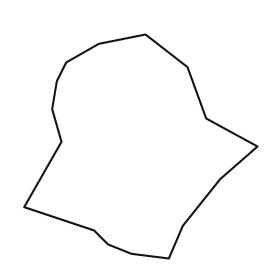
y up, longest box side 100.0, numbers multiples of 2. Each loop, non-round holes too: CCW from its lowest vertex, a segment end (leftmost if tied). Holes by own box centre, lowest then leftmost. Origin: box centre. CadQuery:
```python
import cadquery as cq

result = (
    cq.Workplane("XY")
    .moveTo(12.0, -48.0)
    .lineTo(18.0, -34.0)
    .lineTo(34.0, -14.0)
    .lineTo(50.0, 0.0)
    .lineTo(28.0, 12.0)
    .lineTo(20.0, 34.0)
    .lineTo(2.0, 48.0)
    .lineTo(-18.0, 44.0)
    .lineTo(-32.0, 36.0)
    .lineTo(-36.0, 28.0)
    .lineTo(-38.0, 16.0)
    .lineTo(-34.0, 2.0)
    .lineTo(-50.0, -26.0)
    .lineTo(-20.0, -36.0)
    .lineTo(-14.0, -42.0)
    .lineTo(-4.0, -46.0)
    .close()
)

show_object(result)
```